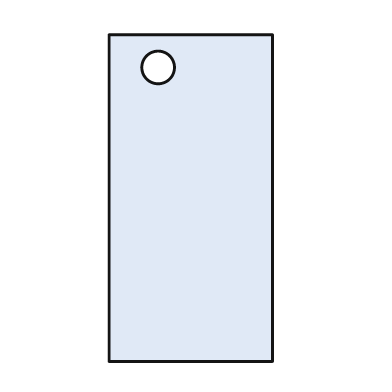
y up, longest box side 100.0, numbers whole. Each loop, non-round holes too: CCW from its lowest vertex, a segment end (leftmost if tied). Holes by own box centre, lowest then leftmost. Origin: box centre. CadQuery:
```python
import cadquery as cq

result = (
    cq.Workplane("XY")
    .moveTo(-25.0, -50.0)
    .lineTo(25.0, -50.0)
    .lineTo(25.0, 50.0)
    .lineTo(-25.0, 50.0)
    .close()
    .moveTo(-10.0, 40.0)
    .circle(5.0)
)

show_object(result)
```